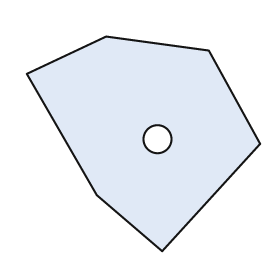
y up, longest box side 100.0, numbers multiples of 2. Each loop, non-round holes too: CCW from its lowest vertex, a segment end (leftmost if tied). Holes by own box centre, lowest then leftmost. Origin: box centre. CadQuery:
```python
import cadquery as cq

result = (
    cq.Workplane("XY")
    .moveTo(8.0, -46.0)
    .lineTo(50.0, 0.0)
    .lineTo(28.0, 40.0)
    .lineTo(-16.0, 46.0)
    .lineTo(-50.0, 30.0)
    .lineTo(-20.0, -22.0)
    .close()
    .moveTo(6.0, 2.0)
    .circle(6.0)
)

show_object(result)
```